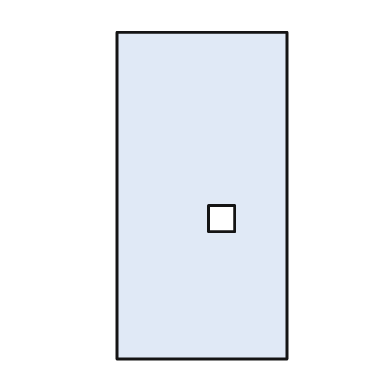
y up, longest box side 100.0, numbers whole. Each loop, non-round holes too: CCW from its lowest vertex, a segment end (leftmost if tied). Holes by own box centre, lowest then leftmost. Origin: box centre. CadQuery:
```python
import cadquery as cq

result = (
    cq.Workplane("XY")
    .moveTo(-26.0, -50.0)
    .lineTo(26.0, -50.0)
    .lineTo(26.0, 50.0)
    .lineTo(-26.0, 50.0)
    .close()
    .moveTo(2.0, -11.0)
    .lineTo(10.0, -11.0)
    .lineTo(10.0, -3.0)
    .lineTo(2.0, -3.0)
    .close()
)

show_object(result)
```